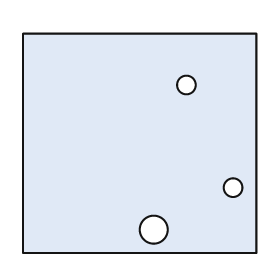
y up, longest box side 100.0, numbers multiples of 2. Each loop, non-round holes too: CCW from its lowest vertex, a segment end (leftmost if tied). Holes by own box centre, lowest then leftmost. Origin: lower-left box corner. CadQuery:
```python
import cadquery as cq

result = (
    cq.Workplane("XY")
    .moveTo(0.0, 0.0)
    .lineTo(100.0, 0.0)
    .lineTo(100.0, 94.0)
    .lineTo(0.0, 94.0)
    .close()
    .moveTo(56.0, 10.0)
    .circle(6.0)
    .moveTo(90.0, 28.0)
    .circle(4.0)
    .moveTo(70.0, 72.0)
    .circle(4.0)
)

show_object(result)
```